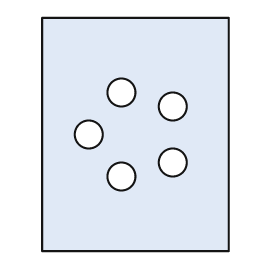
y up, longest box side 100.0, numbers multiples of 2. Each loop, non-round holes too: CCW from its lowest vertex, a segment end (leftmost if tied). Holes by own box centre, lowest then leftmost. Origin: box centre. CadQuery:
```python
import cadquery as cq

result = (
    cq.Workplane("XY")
    .moveTo(-40.0, -50.0)
    .lineTo(40.0, -50.0)
    .lineTo(40.0, 50.0)
    .lineTo(-40.0, 50.0)
    .close()
    .moveTo(-6.0, -18.0)
    .circle(6.0)
    .moveTo(16.0, -12.0)
    .circle(6.0)
    .moveTo(-20.0, 0.0)
    .circle(6.0)
    .moveTo(16.0, 12.0)
    .circle(6.0)
    .moveTo(-6.0, 18.0)
    .circle(6.0)
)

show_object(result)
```